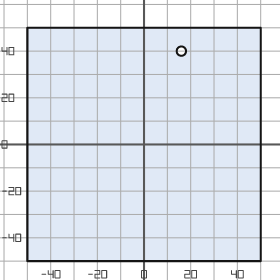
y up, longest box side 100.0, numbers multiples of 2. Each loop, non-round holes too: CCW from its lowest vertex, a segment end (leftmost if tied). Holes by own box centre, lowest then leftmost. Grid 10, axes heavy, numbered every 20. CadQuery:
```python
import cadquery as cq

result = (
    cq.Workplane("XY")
    .moveTo(-50.0, -50.0)
    .lineTo(50.0, -50.0)
    .lineTo(50.0, 50.0)
    .lineTo(-50.0, 50.0)
    .close()
    .moveTo(16.0, 40.0)
    .circle(2.0)
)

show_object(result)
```